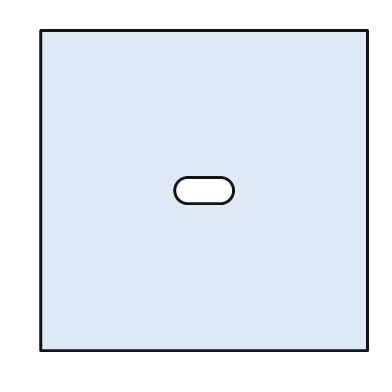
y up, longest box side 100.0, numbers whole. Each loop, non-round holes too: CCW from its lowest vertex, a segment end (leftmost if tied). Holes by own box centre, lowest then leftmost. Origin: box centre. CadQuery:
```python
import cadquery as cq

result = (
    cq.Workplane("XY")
    .moveTo(-50.0, -49.0)
    .lineTo(50.0, -49.0)
    .lineTo(50.0, 49.0)
    .lineTo(-50.0, 49.0)
    .close()
    .moveTo(-5.0, -4.0)
    .lineTo(5.0, -4.0)
    .threePointArc((9.0, 0.0), (5.0, 4.0))
    .lineTo(-5.0, 4.0)
    .threePointArc((-9.0, 0.0), (-5.0, -4.0))
    .close()
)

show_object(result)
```